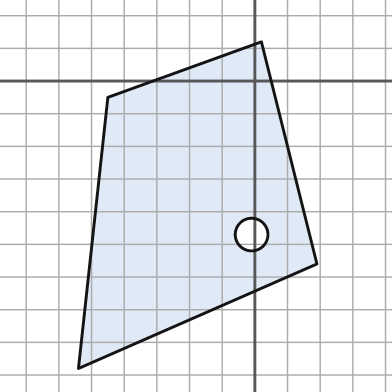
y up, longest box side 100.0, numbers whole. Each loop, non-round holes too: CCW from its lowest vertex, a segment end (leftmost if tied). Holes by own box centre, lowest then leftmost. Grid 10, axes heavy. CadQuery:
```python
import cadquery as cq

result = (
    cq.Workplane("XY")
    .moveTo(-54.0, -88.0)
    .lineTo(19.0, -56.0)
    .lineTo(2.0, 12.0)
    .lineTo(-45.0, -5.0)
    .close()
    .moveTo(-1.0, -47.0)
    .circle(5.0)
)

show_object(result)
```